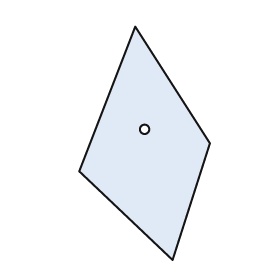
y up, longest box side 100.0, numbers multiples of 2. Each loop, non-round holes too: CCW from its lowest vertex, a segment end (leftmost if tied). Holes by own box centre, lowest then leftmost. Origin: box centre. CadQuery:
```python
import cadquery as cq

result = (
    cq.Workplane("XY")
    .moveTo(12.0, -50.0)
    .lineTo(28.0, 0.0)
    .lineTo(-4.0, 50.0)
    .lineTo(-28.0, -12.0)
    .close()
    .moveTo(0.0, 6.0)
    .circle(2.0)
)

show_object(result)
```